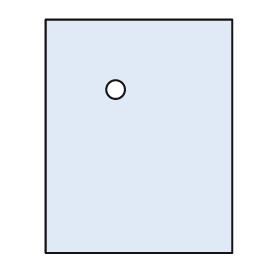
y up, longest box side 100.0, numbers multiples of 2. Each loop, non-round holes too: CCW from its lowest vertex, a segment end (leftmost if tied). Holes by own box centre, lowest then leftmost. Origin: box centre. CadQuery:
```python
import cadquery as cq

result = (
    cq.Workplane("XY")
    .moveTo(-40.0, -50.0)
    .lineTo(40.0, -50.0)
    .lineTo(40.0, 50.0)
    .lineTo(-40.0, 50.0)
    .close()
    .moveTo(-10.0, 20.0)
    .circle(4.0)
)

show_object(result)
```